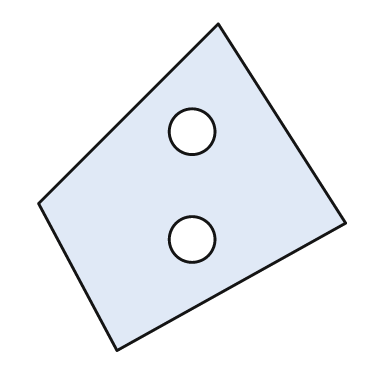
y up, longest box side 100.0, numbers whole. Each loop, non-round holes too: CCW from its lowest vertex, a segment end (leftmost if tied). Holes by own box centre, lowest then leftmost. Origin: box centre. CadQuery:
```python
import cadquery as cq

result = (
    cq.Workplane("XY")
    .moveTo(-23.0, -50.0)
    .lineTo(47.0, -11.0)
    .lineTo(8.0, 50.0)
    .lineTo(-47.0, -5.0)
    .close()
    .moveTo(0.0, -16.0)
    .circle(7.0)
    .moveTo(0.0, 17.0)
    .circle(7.0)
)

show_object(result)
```